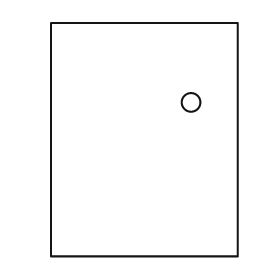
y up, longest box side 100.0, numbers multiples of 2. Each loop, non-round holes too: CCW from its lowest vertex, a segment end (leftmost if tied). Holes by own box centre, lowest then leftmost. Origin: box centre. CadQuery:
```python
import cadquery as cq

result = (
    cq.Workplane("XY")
    .moveTo(-40.0, -50.0)
    .lineTo(40.0, -50.0)
    .lineTo(40.0, 50.0)
    .lineTo(-40.0, 50.0)
    .close()
    .moveTo(20.0, 16.0)
    .circle(4.0)
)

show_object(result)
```